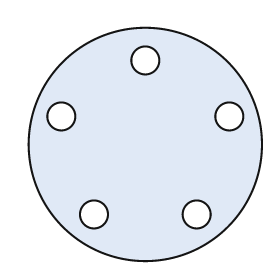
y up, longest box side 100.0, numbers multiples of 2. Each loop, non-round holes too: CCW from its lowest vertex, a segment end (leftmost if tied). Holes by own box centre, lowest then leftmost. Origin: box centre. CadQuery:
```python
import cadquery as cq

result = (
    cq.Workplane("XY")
    .moveTo(0.0, 0.0)
    .circle(50.0)
    .moveTo(-22.0, -30.0)
    .circle(6.0)
    .moveTo(22.0, -30.0)
    .circle(6.0)
    .moveTo(-36.0, 12.0)
    .circle(6.0)
    .moveTo(36.0, 12.0)
    .circle(6.0)
    .moveTo(0.0, 36.0)
    .circle(6.0)
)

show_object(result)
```